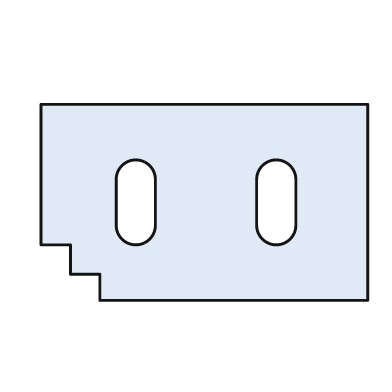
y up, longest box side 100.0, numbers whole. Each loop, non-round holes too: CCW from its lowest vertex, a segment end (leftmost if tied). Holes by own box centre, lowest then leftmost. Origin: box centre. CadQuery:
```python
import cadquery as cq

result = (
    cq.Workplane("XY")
    .moveTo(-32.0, -30.0)
    .lineTo(50.0, -30.0)
    .lineTo(50.0, 30.0)
    .lineTo(-50.0, 30.0)
    .lineTo(-50.0, -13.0)
    .lineTo(-41.0, -13.0)
    .lineTo(-41.0, -22.0)
    .lineTo(-32.0, -22.0)
    .close()
    .moveTo(-27.0, -7.0)
    .threePointArc((-21.0, -13.0), (-15.0, -7.0))
    .lineTo(-15.0, 7.0)
    .threePointArc((-21.0, 13.0), (-27.0, 7.0))
    .close()
    .moveTo(16.0, -7.0)
    .threePointArc((22.0, -13.0), (28.0, -7.0))
    .lineTo(28.0, 7.0)
    .threePointArc((22.0, 13.0), (16.0, 7.0))
    .close()
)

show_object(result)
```